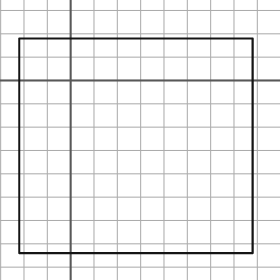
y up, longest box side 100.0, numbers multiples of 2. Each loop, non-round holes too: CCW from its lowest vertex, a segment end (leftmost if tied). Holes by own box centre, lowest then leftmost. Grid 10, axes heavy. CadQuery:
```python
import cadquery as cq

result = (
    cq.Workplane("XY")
    .moveTo(-22.0, -74.0)
    .lineTo(78.0, -74.0)
    .lineTo(78.0, 18.0)
    .lineTo(-22.0, 18.0)
    .close()
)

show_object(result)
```